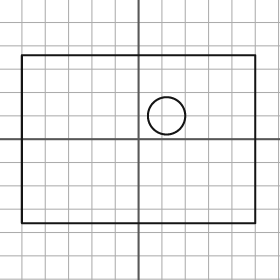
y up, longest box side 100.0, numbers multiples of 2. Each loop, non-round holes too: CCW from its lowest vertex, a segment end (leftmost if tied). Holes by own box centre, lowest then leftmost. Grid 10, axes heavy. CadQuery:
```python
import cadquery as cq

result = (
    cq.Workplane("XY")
    .moveTo(-50.0, -36.0)
    .lineTo(50.0, -36.0)
    .lineTo(50.0, 36.0)
    .lineTo(-50.0, 36.0)
    .close()
    .moveTo(12.0, 10.0)
    .circle(8.0)
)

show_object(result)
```